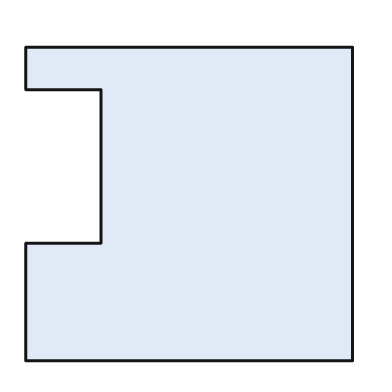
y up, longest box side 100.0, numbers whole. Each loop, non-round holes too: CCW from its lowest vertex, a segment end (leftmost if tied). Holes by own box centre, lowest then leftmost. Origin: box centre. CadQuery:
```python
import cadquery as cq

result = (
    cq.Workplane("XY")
    .moveTo(-50.0, -48.0)
    .lineTo(50.0, -48.0)
    .lineTo(50.0, 48.0)
    .lineTo(-50.0, 48.0)
    .lineTo(-50.0, 35.0)
    .lineTo(-27.0, 35.0)
    .lineTo(-27.0, -12.0)
    .lineTo(-50.0, -12.0)
    .close()
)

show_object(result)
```